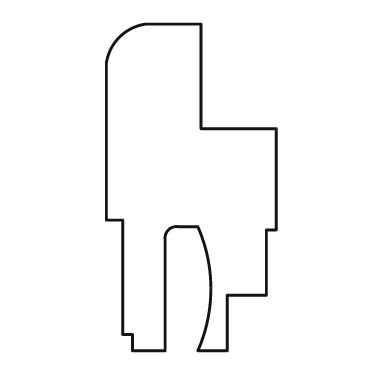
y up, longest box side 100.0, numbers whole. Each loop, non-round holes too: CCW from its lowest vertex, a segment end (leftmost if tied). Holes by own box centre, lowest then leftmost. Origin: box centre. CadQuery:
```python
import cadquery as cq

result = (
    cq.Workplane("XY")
    .moveTo(-18.0, -50.0)
    .lineTo(-8.0, -50.0)
    .lineTo(-8.0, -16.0)
    .threePointArc((-7.0, -13.0), (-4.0, -12.0))
    .lineTo(2.0, -12.0)
    .threePointArc((6.0, -31.0), (2.0, -50.0))
    .lineTo(11.0, -50.0)
    .lineTo(11.0, -33.0)
    .lineTo(23.0, -33.0)
    .lineTo(23.0, -13.0)
    .lineTo(26.0, -13.0)
    .lineTo(26.0, 18.0)
    .lineTo(3.0, 18.0)
    .lineTo(3.0, 50.0)
    .lineTo(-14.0, 50.0)
    .threePointArc((-22.0, 46.0), (-26.0, 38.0))
    .lineTo(-26.0, -10.0)
    .lineTo(-21.0, -10.0)
    .lineTo(-21.0, -45.0)
    .lineTo(-18.0, -45.0)
    .close()
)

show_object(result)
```